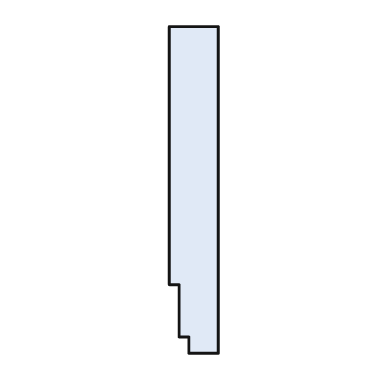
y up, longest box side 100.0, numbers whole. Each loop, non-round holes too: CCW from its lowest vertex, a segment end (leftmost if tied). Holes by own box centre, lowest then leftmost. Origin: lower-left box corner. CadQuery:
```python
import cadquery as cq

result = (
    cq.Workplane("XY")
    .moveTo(6.0, 0.0)
    .lineTo(15.0, 0.0)
    .lineTo(15.0, 100.0)
    .lineTo(0.0, 100.0)
    .lineTo(0.0, 21.0)
    .lineTo(3.0, 21.0)
    .lineTo(3.0, 5.0)
    .lineTo(6.0, 5.0)
    .close()
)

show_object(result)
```